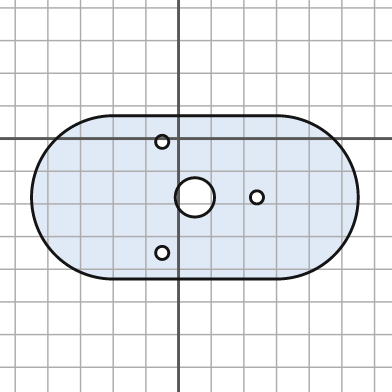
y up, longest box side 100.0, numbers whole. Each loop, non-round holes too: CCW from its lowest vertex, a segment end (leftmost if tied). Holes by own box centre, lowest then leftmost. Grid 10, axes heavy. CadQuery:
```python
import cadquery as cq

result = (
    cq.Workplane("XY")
    .moveTo(-20.0, -43.0)
    .lineTo(30.0, -43.0)
    .threePointArc((55.0, -18.0), (30.0, 7.0))
    .lineTo(-20.0, 7.0)
    .threePointArc((-45.0, -18.0), (-20.0, -43.0))
    .close()
    .moveTo(-5.0, -35.0)
    .circle(2.0)
    .moveTo(5.0, -18.0)
    .circle(6.0)
    .moveTo(24.0, -18.0)
    .circle(2.0)
    .moveTo(-5.0, -1.0)
    .circle(2.0)
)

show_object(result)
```